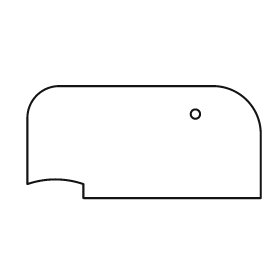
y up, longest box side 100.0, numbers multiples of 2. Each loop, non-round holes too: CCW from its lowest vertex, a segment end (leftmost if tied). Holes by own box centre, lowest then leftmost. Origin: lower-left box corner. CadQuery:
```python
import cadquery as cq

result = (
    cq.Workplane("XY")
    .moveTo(24.0, 0.0)
    .lineTo(100.0, 0.0)
    .lineTo(100.0, 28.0)
    .threePointArc((94.0, 42.0), (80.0, 48.0))
    .lineTo(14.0, 48.0)
    .threePointArc((4.0, 44.0), (0.0, 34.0))
    .lineTo(0.0, 6.0)
    .threePointArc((12.0, 8.0), (24.0, 6.0))
    .close()
    .moveTo(72.0, 36.0)
    .circle(2.0)
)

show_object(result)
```